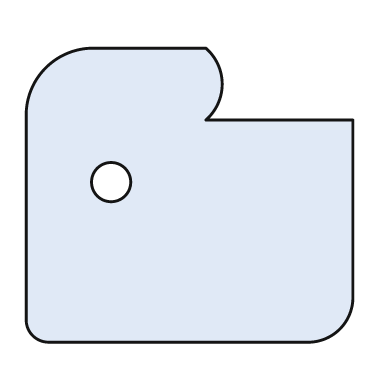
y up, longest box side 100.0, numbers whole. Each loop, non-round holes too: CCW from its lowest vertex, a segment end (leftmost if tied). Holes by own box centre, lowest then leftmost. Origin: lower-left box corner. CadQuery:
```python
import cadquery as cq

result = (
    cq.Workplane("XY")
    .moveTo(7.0, 0.0)
    .lineTo(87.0, 0.0)
    .threePointArc((96.0, 4.0), (100.0, 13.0))
    .lineTo(100.0, 68.0)
    .lineTo(55.0, 68.0)
    .threePointArc((60.0, 79.0), (55.0, 90.0))
    .lineTo(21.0, 90.0)
    .threePointArc((6.0, 84.0), (0.0, 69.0))
    .lineTo(0.0, 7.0)
    .threePointArc((2.0, 2.0), (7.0, 0.0))
    .close()
    .moveTo(26.0, 49.0)
    .circle(6.0)
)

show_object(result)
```